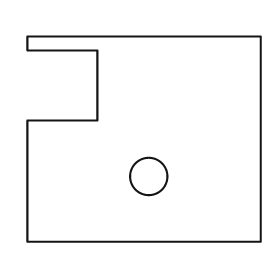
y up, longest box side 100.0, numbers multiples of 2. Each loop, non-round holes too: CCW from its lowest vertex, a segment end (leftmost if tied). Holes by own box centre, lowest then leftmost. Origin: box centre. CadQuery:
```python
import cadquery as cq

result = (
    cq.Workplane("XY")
    .moveTo(-50.0, -44.0)
    .lineTo(50.0, -44.0)
    .lineTo(50.0, 44.0)
    .lineTo(-50.0, 44.0)
    .lineTo(-50.0, 38.0)
    .lineTo(-20.0, 38.0)
    .lineTo(-20.0, 8.0)
    .lineTo(-50.0, 8.0)
    .close()
    .moveTo(2.0, -16.0)
    .circle(8.0)
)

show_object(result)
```